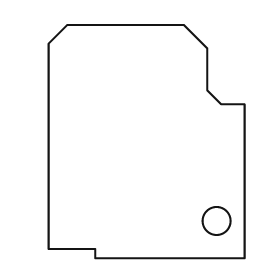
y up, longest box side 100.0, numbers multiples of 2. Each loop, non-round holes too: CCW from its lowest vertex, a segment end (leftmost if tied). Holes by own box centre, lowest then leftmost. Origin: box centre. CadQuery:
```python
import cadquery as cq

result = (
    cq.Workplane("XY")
    .moveTo(-22.0, -50.0)
    .lineTo(42.0, -50.0)
    .lineTo(42.0, 16.0)
    .lineTo(32.0, 16.0)
    .lineTo(26.0, 22.0)
    .lineTo(26.0, 40.0)
    .lineTo(16.0, 50.0)
    .lineTo(-34.0, 50.0)
    .lineTo(-42.0, 42.0)
    .lineTo(-42.0, -46.0)
    .lineTo(-22.0, -46.0)
    .close()
    .moveTo(30.0, -34.0)
    .circle(6.0)
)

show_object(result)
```